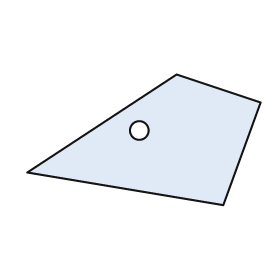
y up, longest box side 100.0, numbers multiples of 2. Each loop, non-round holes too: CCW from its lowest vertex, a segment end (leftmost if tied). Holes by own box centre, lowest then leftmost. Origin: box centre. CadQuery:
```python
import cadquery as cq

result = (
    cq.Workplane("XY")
    .moveTo(34.0, -28.0)
    .lineTo(50.0, 16.0)
    .lineTo(14.0, 28.0)
    .lineTo(-50.0, -14.0)
    .close()
    .moveTo(-2.0, 4.0)
    .circle(4.0)
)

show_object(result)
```